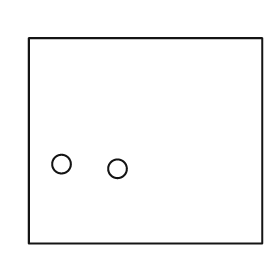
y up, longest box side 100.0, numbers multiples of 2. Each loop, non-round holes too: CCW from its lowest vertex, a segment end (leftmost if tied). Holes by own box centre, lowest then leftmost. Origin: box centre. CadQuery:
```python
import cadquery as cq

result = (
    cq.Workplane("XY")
    .moveTo(-50.0, -44.0)
    .lineTo(50.0, -44.0)
    .lineTo(50.0, 44.0)
    .lineTo(-50.0, 44.0)
    .close()
    .moveTo(-12.0, -12.0)
    .circle(4.0)
    .moveTo(-36.0, -10.0)
    .circle(4.0)
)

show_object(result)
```